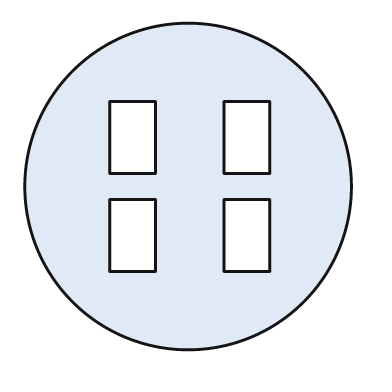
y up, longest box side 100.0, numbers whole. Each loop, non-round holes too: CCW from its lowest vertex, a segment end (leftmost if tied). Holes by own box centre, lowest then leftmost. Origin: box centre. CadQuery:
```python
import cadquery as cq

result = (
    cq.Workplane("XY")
    .moveTo(0.0, 0.0)
    .circle(50.0)
    .moveTo(-24.0, -26.0)
    .lineTo(-10.0, -26.0)
    .lineTo(-10.0, -4.0)
    .lineTo(-24.0, -4.0)
    .close()
    .moveTo(11.0, -26.0)
    .lineTo(25.0, -26.0)
    .lineTo(25.0, -4.0)
    .lineTo(11.0, -4.0)
    .close()
    .moveTo(-24.0, 4.0)
    .lineTo(-10.0, 4.0)
    .lineTo(-10.0, 26.0)
    .lineTo(-24.0, 26.0)
    .close()
    .moveTo(11.0, 4.0)
    .lineTo(25.0, 4.0)
    .lineTo(25.0, 26.0)
    .lineTo(11.0, 26.0)
    .close()
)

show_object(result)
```